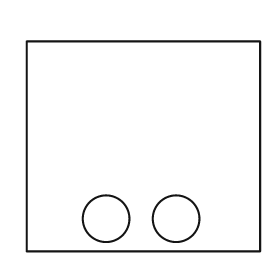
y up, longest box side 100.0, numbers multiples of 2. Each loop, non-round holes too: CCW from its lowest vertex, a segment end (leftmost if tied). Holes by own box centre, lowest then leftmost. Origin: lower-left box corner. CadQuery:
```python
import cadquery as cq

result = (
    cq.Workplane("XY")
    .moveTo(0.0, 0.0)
    .lineTo(100.0, 0.0)
    .lineTo(100.0, 90.0)
    .lineTo(0.0, 90.0)
    .close()
    .moveTo(34.0, 14.0)
    .circle(10.0)
    .moveTo(64.0, 14.0)
    .circle(10.0)
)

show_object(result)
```